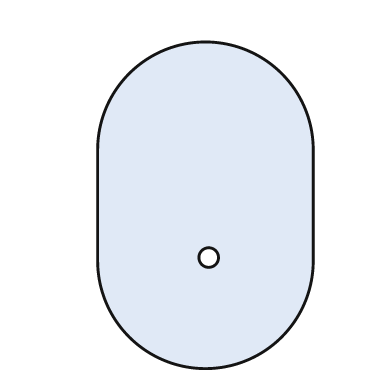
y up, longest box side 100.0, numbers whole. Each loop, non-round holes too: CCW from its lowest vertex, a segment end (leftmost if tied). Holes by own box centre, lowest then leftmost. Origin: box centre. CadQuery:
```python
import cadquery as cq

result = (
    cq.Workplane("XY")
    .moveTo(-33.0, -17.0)
    .threePointArc((0.0, -50.0), (33.0, -17.0))
    .lineTo(33.0, 17.0)
    .threePointArc((0.0, 50.0), (-33.0, 17.0))
    .close()
    .moveTo(1.0, -16.0)
    .circle(3.0)
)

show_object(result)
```